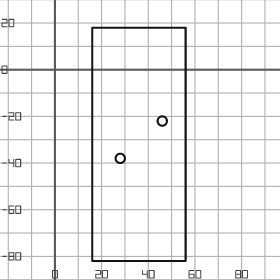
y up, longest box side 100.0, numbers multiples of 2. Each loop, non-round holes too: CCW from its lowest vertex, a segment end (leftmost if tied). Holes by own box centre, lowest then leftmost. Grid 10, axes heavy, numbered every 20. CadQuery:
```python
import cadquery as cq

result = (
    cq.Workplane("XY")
    .moveTo(16.0, -82.0)
    .lineTo(56.0, -82.0)
    .lineTo(56.0, 18.0)
    .lineTo(16.0, 18.0)
    .close()
    .moveTo(28.0, -38.0)
    .circle(2.0)
    .moveTo(46.0, -22.0)
    .circle(2.0)
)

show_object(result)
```